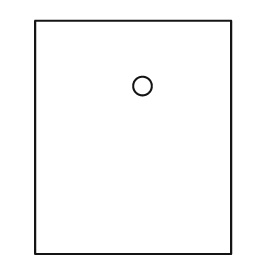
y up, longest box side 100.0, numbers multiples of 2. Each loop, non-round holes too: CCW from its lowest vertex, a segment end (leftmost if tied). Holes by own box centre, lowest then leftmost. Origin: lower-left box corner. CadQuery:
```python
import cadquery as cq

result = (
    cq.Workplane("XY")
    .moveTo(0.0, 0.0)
    .lineTo(84.0, 0.0)
    .lineTo(84.0, 100.0)
    .lineTo(0.0, 100.0)
    .close()
    .moveTo(46.0, 72.0)
    .circle(4.0)
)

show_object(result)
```